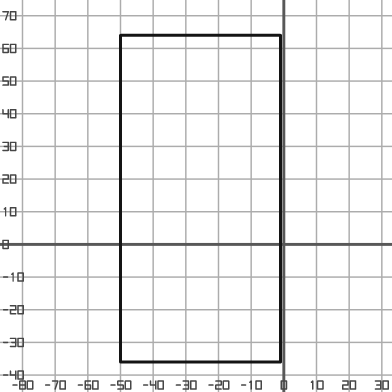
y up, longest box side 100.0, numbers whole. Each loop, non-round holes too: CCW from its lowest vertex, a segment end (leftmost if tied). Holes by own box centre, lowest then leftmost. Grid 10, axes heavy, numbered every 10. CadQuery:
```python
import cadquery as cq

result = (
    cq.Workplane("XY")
    .moveTo(-50.0, -36.0)
    .lineTo(-1.0, -36.0)
    .lineTo(-1.0, 64.0)
    .lineTo(-50.0, 64.0)
    .close()
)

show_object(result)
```